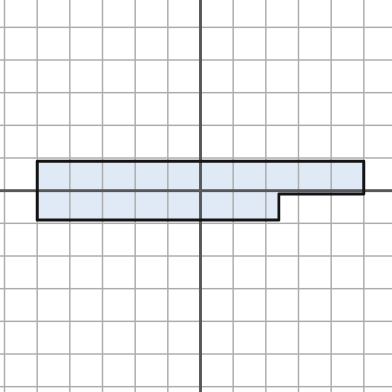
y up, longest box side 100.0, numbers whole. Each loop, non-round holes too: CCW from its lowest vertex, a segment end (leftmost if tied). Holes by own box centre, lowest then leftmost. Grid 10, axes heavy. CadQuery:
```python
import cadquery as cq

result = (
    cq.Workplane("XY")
    .moveTo(-50.0, -9.0)
    .lineTo(24.0, -9.0)
    .lineTo(24.0, -1.0)
    .lineTo(50.0, -1.0)
    .lineTo(50.0, 9.0)
    .lineTo(-50.0, 9.0)
    .close()
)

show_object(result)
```